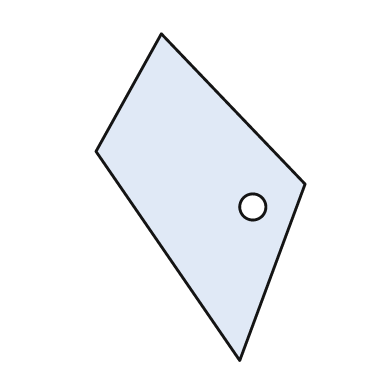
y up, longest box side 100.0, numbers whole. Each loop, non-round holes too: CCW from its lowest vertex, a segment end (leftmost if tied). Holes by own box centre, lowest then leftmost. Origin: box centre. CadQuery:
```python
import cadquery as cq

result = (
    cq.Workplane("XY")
    .moveTo(12.0, -50.0)
    .lineTo(32.0, 4.0)
    .lineTo(-12.0, 50.0)
    .lineTo(-32.0, 14.0)
    .close()
    .moveTo(16.0, -3.0)
    .circle(4.0)
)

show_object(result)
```